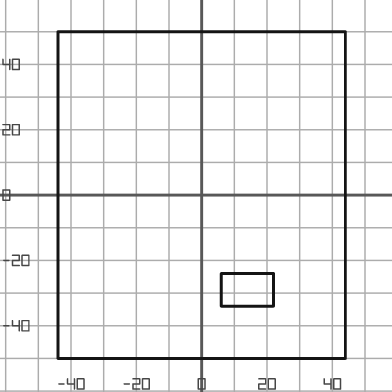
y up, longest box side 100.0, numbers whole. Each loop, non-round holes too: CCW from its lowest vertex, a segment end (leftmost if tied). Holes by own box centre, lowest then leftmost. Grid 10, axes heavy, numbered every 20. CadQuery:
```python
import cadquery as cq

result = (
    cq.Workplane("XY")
    .moveTo(-44.0, -50.0)
    .lineTo(44.0, -50.0)
    .lineTo(44.0, 50.0)
    .lineTo(-44.0, 50.0)
    .close()
    .moveTo(6.0, -34.0)
    .lineTo(22.0, -34.0)
    .lineTo(22.0, -24.0)
    .lineTo(6.0, -24.0)
    .close()
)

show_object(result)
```